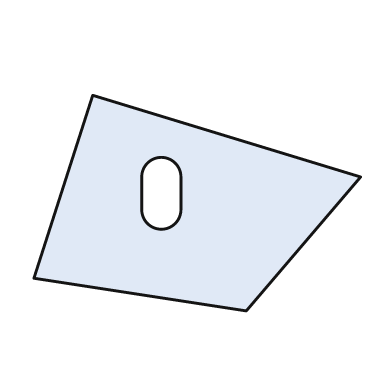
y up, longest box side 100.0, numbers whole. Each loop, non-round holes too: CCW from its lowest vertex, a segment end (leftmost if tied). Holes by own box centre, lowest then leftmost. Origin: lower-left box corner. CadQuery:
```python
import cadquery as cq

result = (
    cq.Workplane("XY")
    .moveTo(65.0, 0.0)
    .lineTo(100.0, 41.0)
    .lineTo(18.0, 66.0)
    .lineTo(0.0, 10.0)
    .close()
    .moveTo(33.0, 31.0)
    .threePointArc((39.0, 25.0), (45.0, 31.0))
    .lineTo(45.0, 41.0)
    .threePointArc((39.0, 47.0), (33.0, 41.0))
    .close()
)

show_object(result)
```